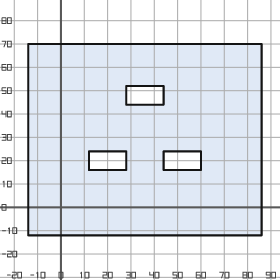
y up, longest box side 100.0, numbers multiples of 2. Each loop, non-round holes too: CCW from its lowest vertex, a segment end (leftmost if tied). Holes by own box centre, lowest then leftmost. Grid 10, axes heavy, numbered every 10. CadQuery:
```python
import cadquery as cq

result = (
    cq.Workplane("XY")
    .moveTo(-14.0, -12.0)
    .lineTo(86.0, -12.0)
    .lineTo(86.0, 70.0)
    .lineTo(-14.0, 70.0)
    .close()
    .moveTo(12.0, 16.0)
    .lineTo(28.0, 16.0)
    .lineTo(28.0, 24.0)
    .lineTo(12.0, 24.0)
    .close()
    .moveTo(44.0, 16.0)
    .lineTo(60.0, 16.0)
    .lineTo(60.0, 24.0)
    .lineTo(44.0, 24.0)
    .close()
    .moveTo(28.0, 44.0)
    .lineTo(44.0, 44.0)
    .lineTo(44.0, 52.0)
    .lineTo(28.0, 52.0)
    .close()
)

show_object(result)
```